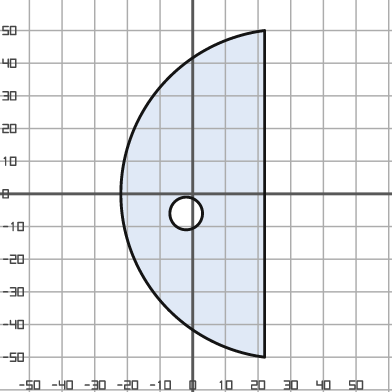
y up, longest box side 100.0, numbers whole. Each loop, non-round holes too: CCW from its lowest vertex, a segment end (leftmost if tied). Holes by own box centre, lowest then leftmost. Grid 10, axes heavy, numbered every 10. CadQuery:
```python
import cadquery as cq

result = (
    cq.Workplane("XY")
    .moveTo(22.0, -50.0)
    .lineTo(22.0, 50.0)
    .threePointArc((-22.0, 0.0), (22.0, -50.0))
    .close()
    .moveTo(-2.0, -6.0)
    .circle(5.0)
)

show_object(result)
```